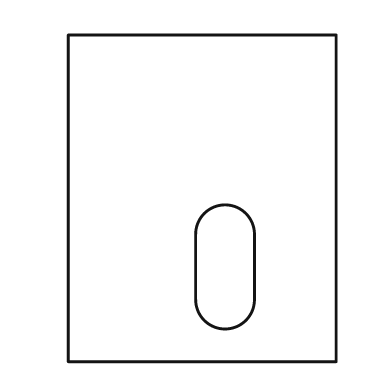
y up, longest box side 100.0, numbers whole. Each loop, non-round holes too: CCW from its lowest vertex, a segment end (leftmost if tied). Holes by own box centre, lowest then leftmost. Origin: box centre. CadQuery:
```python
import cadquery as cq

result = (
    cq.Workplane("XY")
    .moveTo(-41.0, -50.0)
    .lineTo(41.0, -50.0)
    .lineTo(41.0, 50.0)
    .lineTo(-41.0, 50.0)
    .close()
    .moveTo(-2.0, -31.0)
    .threePointArc((7.0, -40.0), (16.0, -31.0))
    .lineTo(16.0, -11.0)
    .threePointArc((7.0, -2.0), (-2.0, -11.0))
    .close()
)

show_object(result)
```